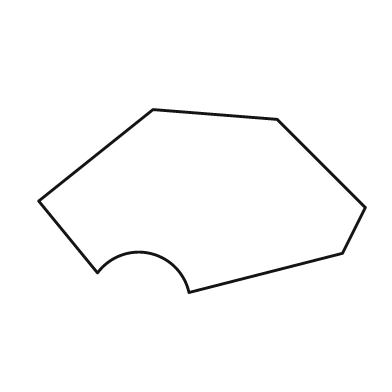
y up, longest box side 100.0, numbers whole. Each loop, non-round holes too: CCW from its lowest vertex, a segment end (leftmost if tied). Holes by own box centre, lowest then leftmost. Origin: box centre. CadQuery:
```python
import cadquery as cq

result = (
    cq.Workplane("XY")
    .moveTo(-4.0, -28.0)
    .lineTo(43.0, -16.0)
    .lineTo(50.0, -2.0)
    .lineTo(23.0, 25.0)
    .lineTo(-15.0, 28.0)
    .lineTo(-50.0, 0.0)
    .lineTo(-32.0, -22.0)
    .threePointArc((-16.0, -16.0), (-4.0, -28.0))
    .close()
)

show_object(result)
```